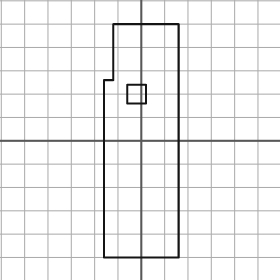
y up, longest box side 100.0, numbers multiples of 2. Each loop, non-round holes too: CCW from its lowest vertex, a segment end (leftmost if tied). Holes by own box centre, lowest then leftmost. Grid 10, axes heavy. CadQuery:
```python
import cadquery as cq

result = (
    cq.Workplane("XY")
    .moveTo(-16.0, -50.0)
    .lineTo(16.0, -50.0)
    .lineTo(16.0, 50.0)
    .lineTo(-12.0, 50.0)
    .lineTo(-12.0, 26.0)
    .lineTo(-16.0, 26.0)
    .close()
    .moveTo(-6.0, 16.0)
    .lineTo(2.0, 16.0)
    .lineTo(2.0, 24.0)
    .lineTo(-6.0, 24.0)
    .close()
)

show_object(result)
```